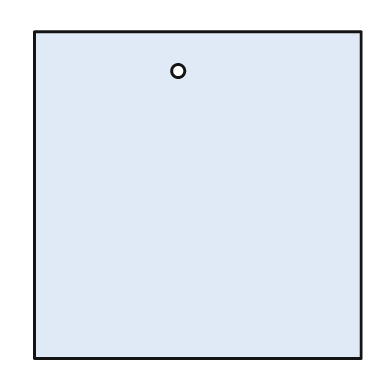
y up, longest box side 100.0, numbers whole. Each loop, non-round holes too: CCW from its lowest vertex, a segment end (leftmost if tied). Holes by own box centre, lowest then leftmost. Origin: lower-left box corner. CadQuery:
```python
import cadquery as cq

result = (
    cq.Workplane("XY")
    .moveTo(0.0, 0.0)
    .lineTo(100.0, 0.0)
    .lineTo(100.0, 100.0)
    .lineTo(0.0, 100.0)
    .close()
    .moveTo(44.0, 88.0)
    .circle(2.0)
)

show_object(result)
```